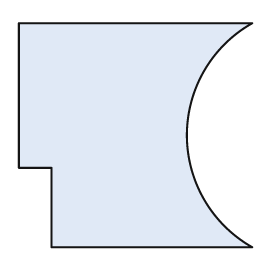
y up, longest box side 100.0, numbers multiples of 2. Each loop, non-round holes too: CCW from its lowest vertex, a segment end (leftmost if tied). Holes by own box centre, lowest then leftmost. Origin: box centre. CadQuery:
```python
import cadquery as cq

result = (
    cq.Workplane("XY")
    .moveTo(-36.0, -48.0)
    .lineTo(50.0, -48.0)
    .threePointArc((22.0, 0.0), (50.0, 48.0))
    .lineTo(-50.0, 48.0)
    .lineTo(-50.0, -14.0)
    .lineTo(-36.0, -14.0)
    .close()
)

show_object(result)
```